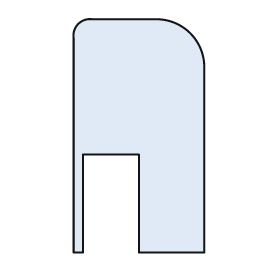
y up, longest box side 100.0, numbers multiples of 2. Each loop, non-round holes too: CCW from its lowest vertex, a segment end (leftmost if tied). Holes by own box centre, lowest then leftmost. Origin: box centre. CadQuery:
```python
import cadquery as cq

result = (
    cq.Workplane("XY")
    .moveTo(-28.0, -50.0)
    .lineTo(-24.0, -50.0)
    .lineTo(-24.0, -8.0)
    .lineTo(0.0, -8.0)
    .lineTo(0.0, -50.0)
    .lineTo(28.0, -50.0)
    .lineTo(28.0, 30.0)
    .threePointArc((22.0, 44.0), (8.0, 50.0))
    .lineTo(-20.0, 50.0)
    .threePointArc((-26.0, 48.0), (-28.0, 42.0))
    .close()
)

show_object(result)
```